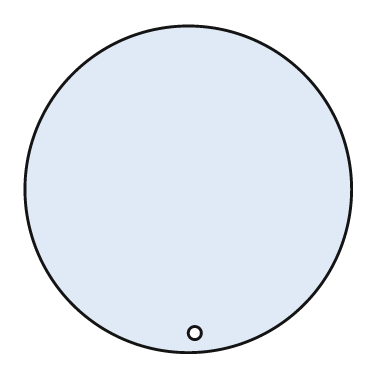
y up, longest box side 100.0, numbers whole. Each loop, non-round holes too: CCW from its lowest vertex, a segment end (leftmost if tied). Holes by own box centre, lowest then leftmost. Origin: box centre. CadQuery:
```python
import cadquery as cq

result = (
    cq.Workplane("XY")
    .moveTo(0.0, 0.0)
    .circle(50.0)
    .moveTo(2.0, -44.0)
    .circle(2.0)
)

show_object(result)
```